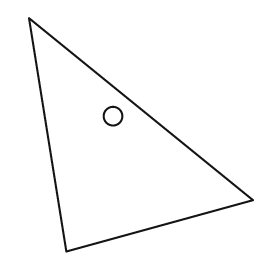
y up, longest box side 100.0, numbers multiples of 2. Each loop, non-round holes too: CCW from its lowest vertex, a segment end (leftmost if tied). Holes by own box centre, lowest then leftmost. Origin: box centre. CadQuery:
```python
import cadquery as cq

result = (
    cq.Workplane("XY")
    .moveTo(-32.0, -50.0)
    .lineTo(48.0, -28.0)
    .lineTo(-48.0, 50.0)
    .close()
    .moveTo(-12.0, 8.0)
    .circle(4.0)
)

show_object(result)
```